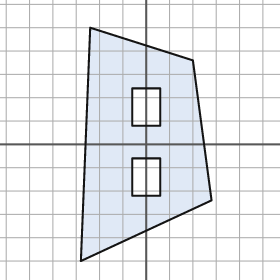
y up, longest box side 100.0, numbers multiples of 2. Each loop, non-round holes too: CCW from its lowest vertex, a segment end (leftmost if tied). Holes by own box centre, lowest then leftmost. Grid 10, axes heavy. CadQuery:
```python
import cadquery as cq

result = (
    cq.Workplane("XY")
    .moveTo(-28.0, -50.0)
    .lineTo(28.0, -24.0)
    .lineTo(20.0, 36.0)
    .lineTo(-24.0, 50.0)
    .close()
    .moveTo(-6.0, -22.0)
    .lineTo(6.0, -22.0)
    .lineTo(6.0, -6.0)
    .lineTo(-6.0, -6.0)
    .close()
    .moveTo(-6.0, 8.0)
    .lineTo(6.0, 8.0)
    .lineTo(6.0, 24.0)
    .lineTo(-6.0, 24.0)
    .close()
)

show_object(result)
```